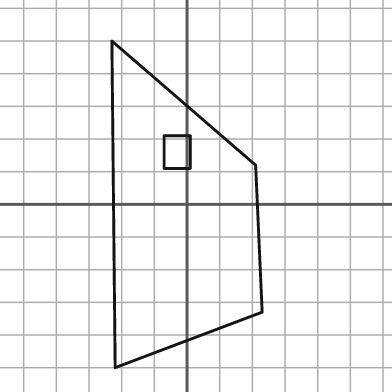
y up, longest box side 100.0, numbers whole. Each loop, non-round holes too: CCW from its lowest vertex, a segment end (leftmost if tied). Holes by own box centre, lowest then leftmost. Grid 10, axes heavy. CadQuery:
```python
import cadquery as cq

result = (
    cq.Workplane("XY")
    .moveTo(-22.0, -50.0)
    .lineTo(23.0, -33.0)
    .lineTo(21.0, 12.0)
    .lineTo(-23.0, 50.0)
    .close()
    .moveTo(-7.0, 11.0)
    .lineTo(1.0, 11.0)
    .lineTo(1.0, 21.0)
    .lineTo(-7.0, 21.0)
    .close()
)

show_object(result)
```